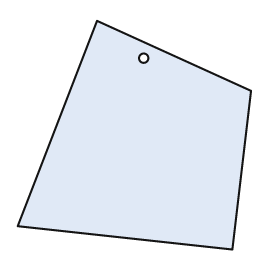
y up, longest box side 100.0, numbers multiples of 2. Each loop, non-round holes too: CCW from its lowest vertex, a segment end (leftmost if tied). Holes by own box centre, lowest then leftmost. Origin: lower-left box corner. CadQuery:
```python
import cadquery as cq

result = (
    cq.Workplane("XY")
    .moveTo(92.0, 0.0)
    .lineTo(100.0, 68.0)
    .lineTo(34.0, 98.0)
    .lineTo(0.0, 10.0)
    .close()
    .moveTo(54.0, 82.0)
    .circle(2.0)
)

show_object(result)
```